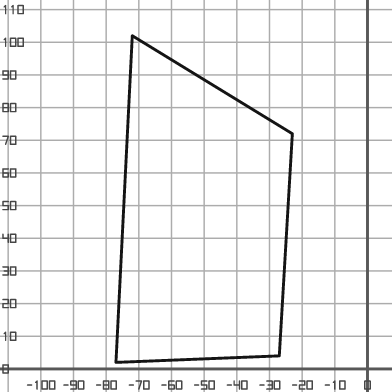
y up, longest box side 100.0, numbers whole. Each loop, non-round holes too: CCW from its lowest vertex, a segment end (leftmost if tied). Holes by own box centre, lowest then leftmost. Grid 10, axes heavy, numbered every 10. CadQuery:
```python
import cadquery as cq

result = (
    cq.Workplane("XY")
    .moveTo(-77.0, 2.0)
    .lineTo(-27.0, 4.0)
    .lineTo(-23.0, 72.0)
    .lineTo(-72.0, 102.0)
    .close()
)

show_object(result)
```